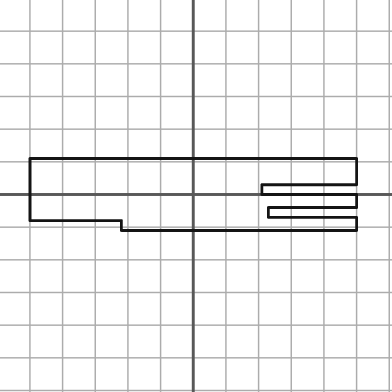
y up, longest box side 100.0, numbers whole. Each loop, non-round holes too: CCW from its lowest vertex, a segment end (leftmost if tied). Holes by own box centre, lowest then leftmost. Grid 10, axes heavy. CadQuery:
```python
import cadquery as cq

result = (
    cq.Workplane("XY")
    .moveTo(-22.0, -11.0)
    .lineTo(50.0, -11.0)
    .lineTo(50.0, -7.0)
    .lineTo(23.0, -7.0)
    .lineTo(23.0, -4.0)
    .lineTo(50.0, -4.0)
    .lineTo(50.0, 0.0)
    .lineTo(21.0, 0.0)
    .lineTo(21.0, 3.0)
    .lineTo(50.0, 3.0)
    .lineTo(50.0, 11.0)
    .lineTo(-50.0, 11.0)
    .lineTo(-50.0, -8.0)
    .lineTo(-22.0, -8.0)
    .close()
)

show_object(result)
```